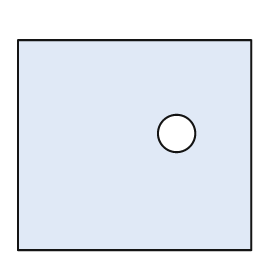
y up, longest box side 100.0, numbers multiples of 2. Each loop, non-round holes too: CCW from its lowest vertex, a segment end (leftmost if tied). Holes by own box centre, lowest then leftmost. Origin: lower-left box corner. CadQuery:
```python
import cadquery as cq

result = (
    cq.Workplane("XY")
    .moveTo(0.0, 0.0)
    .lineTo(100.0, 0.0)
    .lineTo(100.0, 90.0)
    .lineTo(0.0, 90.0)
    .close()
    .moveTo(68.0, 50.0)
    .circle(8.0)
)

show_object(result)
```